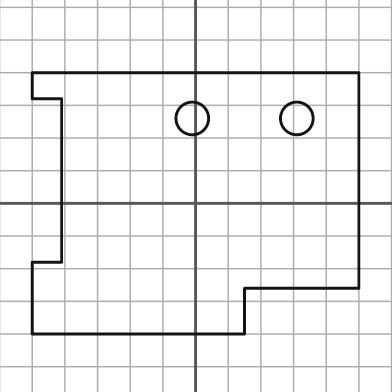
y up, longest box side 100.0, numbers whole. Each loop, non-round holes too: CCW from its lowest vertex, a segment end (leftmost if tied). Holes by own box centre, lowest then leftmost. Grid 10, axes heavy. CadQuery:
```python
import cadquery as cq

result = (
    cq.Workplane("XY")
    .moveTo(-50.0, -40.0)
    .lineTo(15.0, -40.0)
    .lineTo(15.0, -26.0)
    .lineTo(50.0, -26.0)
    .lineTo(50.0, 40.0)
    .lineTo(-50.0, 40.0)
    .lineTo(-50.0, 32.0)
    .lineTo(-41.0, 32.0)
    .lineTo(-41.0, -18.0)
    .lineTo(-50.0, -18.0)
    .close()
    .moveTo(-1.0, 26.0)
    .circle(5.0)
    .moveTo(31.0, 26.0)
    .circle(5.0)
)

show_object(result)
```